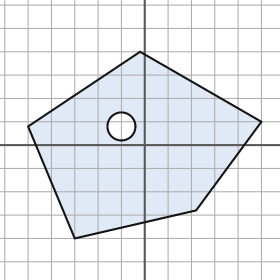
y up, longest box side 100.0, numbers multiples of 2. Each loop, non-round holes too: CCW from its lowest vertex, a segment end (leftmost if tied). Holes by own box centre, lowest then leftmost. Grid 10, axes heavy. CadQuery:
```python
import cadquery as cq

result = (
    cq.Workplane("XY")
    .moveTo(-30.0, -40.0)
    .lineTo(22.0, -28.0)
    .lineTo(50.0, 10.0)
    .lineTo(-2.0, 40.0)
    .lineTo(-50.0, 8.0)
    .close()
    .moveTo(-10.0, 8.0)
    .circle(6.0)
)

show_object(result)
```